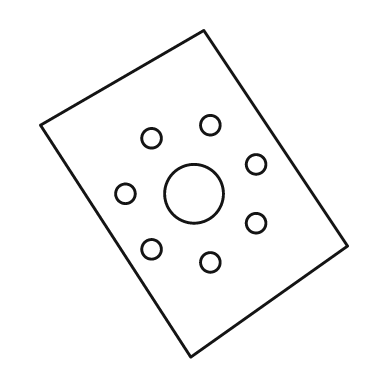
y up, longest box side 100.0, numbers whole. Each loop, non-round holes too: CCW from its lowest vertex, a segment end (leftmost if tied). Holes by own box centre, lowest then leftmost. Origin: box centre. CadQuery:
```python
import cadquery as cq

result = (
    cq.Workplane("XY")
    .moveTo(-1.0, -50.0)
    .lineTo(47.0, -16.0)
    .lineTo(3.0, 50.0)
    .lineTo(-47.0, 21.0)
    .close()
    .moveTo(5.0, -21.0)
    .circle(3.0)
    .moveTo(-13.0, -17.0)
    .circle(3.0)
    .moveTo(19.0, -9.0)
    .circle(3.0)
    .moveTo(-21.0, 0.0)
    .circle(3.0)
    .moveTo(0.0, 0.0)
    .circle(9.0)
    .moveTo(19.0, 9.0)
    .circle(3.0)
    .moveTo(-13.0, 17.0)
    .circle(3.0)
    .moveTo(5.0, 21.0)
    .circle(3.0)
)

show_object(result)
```